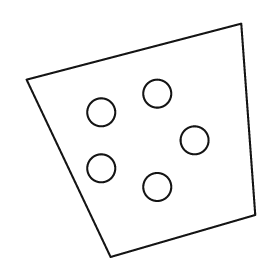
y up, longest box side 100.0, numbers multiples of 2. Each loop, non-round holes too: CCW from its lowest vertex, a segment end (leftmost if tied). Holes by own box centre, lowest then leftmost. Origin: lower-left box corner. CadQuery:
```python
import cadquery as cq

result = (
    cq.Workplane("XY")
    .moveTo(36.0, 0.0)
    .lineTo(98.0, 18.0)
    .lineTo(92.0, 100.0)
    .lineTo(0.0, 76.0)
    .close()
    .moveTo(56.0, 30.0)
    .circle(6.0)
    .moveTo(32.0, 38.0)
    .circle(6.0)
    .moveTo(72.0, 50.0)
    .circle(6.0)
    .moveTo(32.0, 62.0)
    .circle(6.0)
    .moveTo(56.0, 70.0)
    .circle(6.0)
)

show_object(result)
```